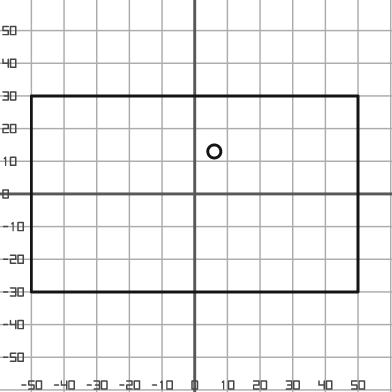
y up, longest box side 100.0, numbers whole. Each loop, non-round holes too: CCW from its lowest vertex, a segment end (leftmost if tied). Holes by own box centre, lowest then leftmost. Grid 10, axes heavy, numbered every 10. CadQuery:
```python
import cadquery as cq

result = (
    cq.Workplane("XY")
    .moveTo(-50.0, -30.0)
    .lineTo(50.0, -30.0)
    .lineTo(50.0, 30.0)
    .lineTo(-50.0, 30.0)
    .close()
    .moveTo(6.0, 13.0)
    .circle(2.0)
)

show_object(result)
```